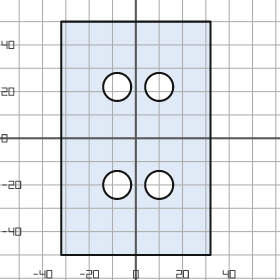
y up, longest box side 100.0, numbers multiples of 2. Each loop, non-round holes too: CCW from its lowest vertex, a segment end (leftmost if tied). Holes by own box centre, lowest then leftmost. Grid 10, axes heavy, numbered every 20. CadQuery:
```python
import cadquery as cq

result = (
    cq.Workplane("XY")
    .moveTo(-32.0, -50.0)
    .lineTo(32.0, -50.0)
    .lineTo(32.0, 50.0)
    .lineTo(-32.0, 50.0)
    .close()
    .moveTo(-8.0, -20.0)
    .circle(6.0)
    .moveTo(10.0, -20.0)
    .circle(6.0)
    .moveTo(-8.0, 22.0)
    .circle(6.0)
    .moveTo(10.0, 22.0)
    .circle(6.0)
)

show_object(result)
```